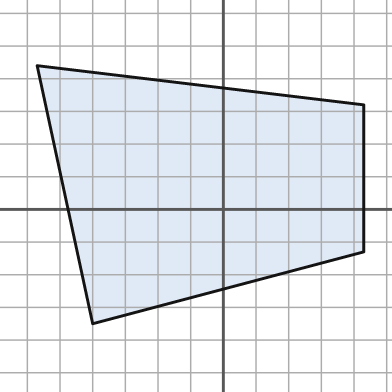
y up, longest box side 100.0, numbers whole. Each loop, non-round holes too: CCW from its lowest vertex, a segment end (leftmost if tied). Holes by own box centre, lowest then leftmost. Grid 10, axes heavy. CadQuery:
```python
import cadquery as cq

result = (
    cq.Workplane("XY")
    .moveTo(-40.0, -35.0)
    .lineTo(43.0, -13.0)
    .lineTo(43.0, 32.0)
    .lineTo(-57.0, 44.0)
    .close()
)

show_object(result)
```